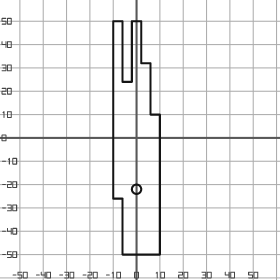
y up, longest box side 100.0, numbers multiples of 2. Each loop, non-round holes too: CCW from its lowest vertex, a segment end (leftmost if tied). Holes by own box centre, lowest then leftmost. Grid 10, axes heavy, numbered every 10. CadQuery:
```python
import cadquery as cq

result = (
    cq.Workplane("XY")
    .moveTo(-6.0, -50.0)
    .lineTo(10.0, -50.0)
    .lineTo(10.0, 10.0)
    .lineTo(6.0, 10.0)
    .lineTo(6.0, 32.0)
    .lineTo(2.0, 32.0)
    .lineTo(2.0, 50.0)
    .lineTo(-2.0, 50.0)
    .lineTo(-2.0, 24.0)
    .lineTo(-6.0, 24.0)
    .lineTo(-6.0, 50.0)
    .lineTo(-10.0, 50.0)
    .lineTo(-10.0, -26.0)
    .lineTo(-6.0, -26.0)
    .close()
    .moveTo(0.0, -22.0)
    .circle(2.0)
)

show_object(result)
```